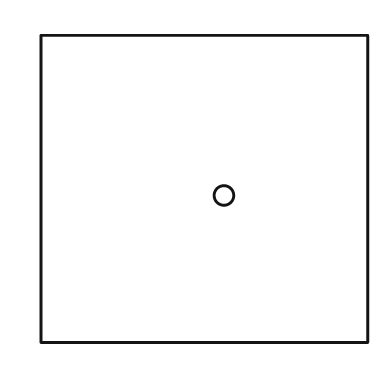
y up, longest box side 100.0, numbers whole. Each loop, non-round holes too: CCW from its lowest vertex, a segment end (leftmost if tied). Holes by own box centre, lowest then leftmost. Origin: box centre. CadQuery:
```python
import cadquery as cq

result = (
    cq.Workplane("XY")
    .moveTo(-50.0, -47.0)
    .lineTo(50.0, -47.0)
    .lineTo(50.0, 47.0)
    .lineTo(-50.0, 47.0)
    .close()
    .moveTo(6.0, -2.0)
    .circle(3.0)
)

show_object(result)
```